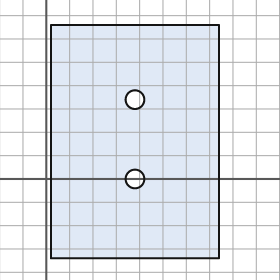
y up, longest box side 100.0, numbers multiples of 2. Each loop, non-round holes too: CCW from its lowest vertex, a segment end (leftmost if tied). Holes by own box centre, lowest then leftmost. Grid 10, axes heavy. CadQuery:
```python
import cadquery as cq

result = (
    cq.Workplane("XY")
    .moveTo(2.0, -34.0)
    .lineTo(74.0, -34.0)
    .lineTo(74.0, 66.0)
    .lineTo(2.0, 66.0)
    .close()
    .moveTo(38.0, 0.0)
    .circle(4.0)
    .moveTo(38.0, 34.0)
    .circle(4.0)
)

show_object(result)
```